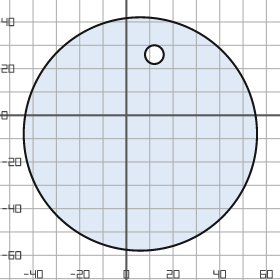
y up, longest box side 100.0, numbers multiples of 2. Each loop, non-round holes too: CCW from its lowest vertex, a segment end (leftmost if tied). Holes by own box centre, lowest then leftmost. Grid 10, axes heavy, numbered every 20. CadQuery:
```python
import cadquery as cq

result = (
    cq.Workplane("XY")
    .moveTo(6.0, -8.0)
    .circle(50.0)
    .moveTo(12.0, 26.0)
    .circle(4.0)
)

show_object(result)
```